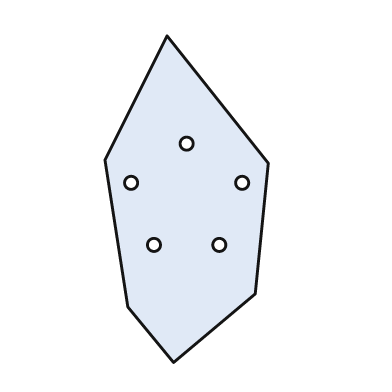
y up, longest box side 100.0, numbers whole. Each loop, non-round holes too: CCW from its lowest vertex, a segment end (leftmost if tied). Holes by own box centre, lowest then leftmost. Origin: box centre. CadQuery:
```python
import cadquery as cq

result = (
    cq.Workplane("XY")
    .moveTo(-4.0, -50.0)
    .lineTo(21.0, -29.0)
    .lineTo(25.0, 11.0)
    .lineTo(-6.0, 50.0)
    .lineTo(-25.0, 12.0)
    .lineTo(-18.0, -33.0)
    .close()
    .moveTo(-10.0, -14.0)
    .circle(2.0)
    .moveTo(10.0, -14.0)
    .circle(2.0)
    .moveTo(-17.0, 5.0)
    .circle(2.0)
    .moveTo(17.0, 5.0)
    .circle(2.0)
    .moveTo(0.0, 17.0)
    .circle(2.0)
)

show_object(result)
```